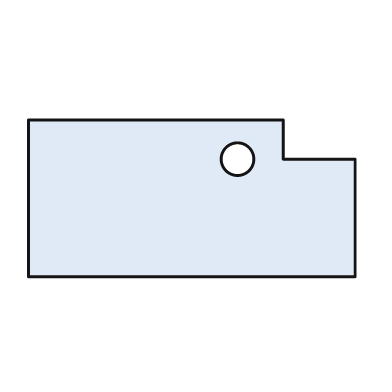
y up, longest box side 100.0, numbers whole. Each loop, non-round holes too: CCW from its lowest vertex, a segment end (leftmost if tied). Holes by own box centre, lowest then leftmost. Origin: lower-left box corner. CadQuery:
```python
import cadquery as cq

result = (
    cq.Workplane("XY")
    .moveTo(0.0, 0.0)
    .lineTo(100.0, 0.0)
    .lineTo(100.0, 36.0)
    .lineTo(78.0, 36.0)
    .lineTo(78.0, 48.0)
    .lineTo(0.0, 48.0)
    .close()
    .moveTo(64.0, 36.0)
    .circle(5.0)
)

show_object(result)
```